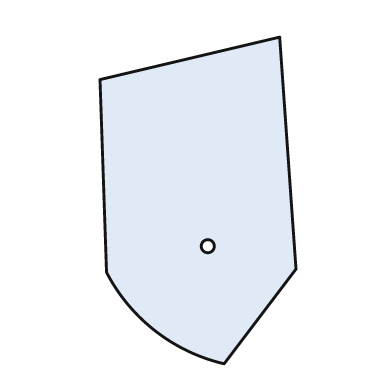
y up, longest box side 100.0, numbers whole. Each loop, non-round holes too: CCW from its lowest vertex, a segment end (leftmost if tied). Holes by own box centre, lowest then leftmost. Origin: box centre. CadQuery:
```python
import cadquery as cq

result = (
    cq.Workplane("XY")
    .moveTo(8.0, -50.0)
    .lineTo(30.0, -21.0)
    .lineTo(25.0, 50.0)
    .lineTo(-30.0, 37.0)
    .lineTo(-28.0, -22.0)
    .threePointArc((-13.0, -40.0), (8.0, -50.0))
    .close()
    .moveTo(3.0, -14.0)
    .circle(2.0)
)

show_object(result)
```